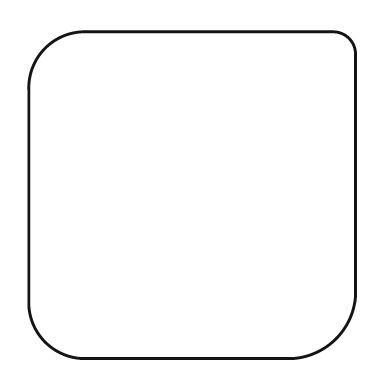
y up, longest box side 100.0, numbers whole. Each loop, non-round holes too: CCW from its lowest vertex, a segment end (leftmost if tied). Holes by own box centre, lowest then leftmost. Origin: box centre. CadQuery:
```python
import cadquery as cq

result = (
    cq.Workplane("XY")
    .moveTo(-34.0, -50.0)
    .lineTo(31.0, -50.0)
    .threePointArc((44.0, -44.0), (50.0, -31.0))
    .lineTo(50.0, 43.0)
    .threePointArc((48.0, 48.0), (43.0, 50.0))
    .lineTo(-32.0, 50.0)
    .threePointArc((-45.0, 45.0), (-50.0, 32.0))
    .lineTo(-50.0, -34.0)
    .threePointArc((-45.0, -45.0), (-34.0, -50.0))
    .close()
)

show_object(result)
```